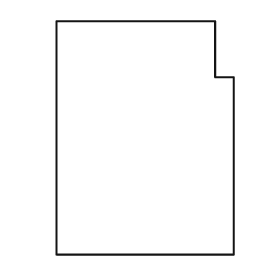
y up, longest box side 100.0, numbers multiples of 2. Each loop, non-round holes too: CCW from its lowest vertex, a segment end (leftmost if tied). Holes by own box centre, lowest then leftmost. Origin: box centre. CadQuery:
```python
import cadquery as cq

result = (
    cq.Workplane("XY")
    .moveTo(-38.0, -50.0)
    .lineTo(38.0, -50.0)
    .lineTo(38.0, 26.0)
    .lineTo(30.0, 26.0)
    .lineTo(30.0, 50.0)
    .lineTo(-38.0, 50.0)
    .close()
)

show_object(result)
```